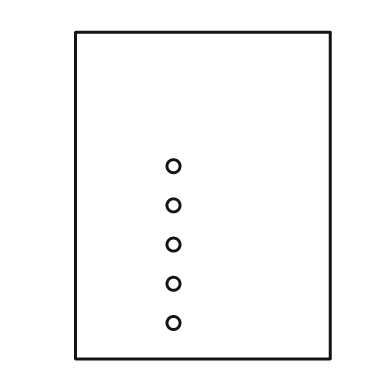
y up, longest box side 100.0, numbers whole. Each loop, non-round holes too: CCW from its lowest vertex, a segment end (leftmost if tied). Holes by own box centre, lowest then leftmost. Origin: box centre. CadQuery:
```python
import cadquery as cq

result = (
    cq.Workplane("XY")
    .moveTo(-39.0, -50.0)
    .lineTo(39.0, -50.0)
    .lineTo(39.0, 50.0)
    .lineTo(-39.0, 50.0)
    .close()
    .moveTo(-9.0, -39.0)
    .circle(2.0)
    .moveTo(-9.0, -27.0)
    .circle(2.0)
    .moveTo(-9.0, -15.0)
    .circle(2.0)
    .moveTo(-9.0, -3.0)
    .circle(2.0)
    .moveTo(-9.0, 9.0)
    .circle(2.0)
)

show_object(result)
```